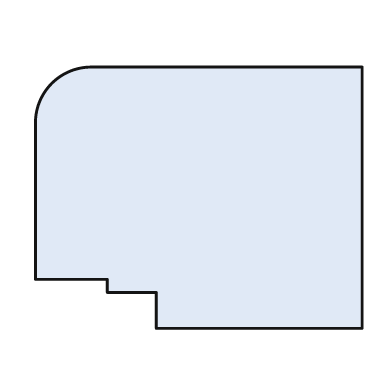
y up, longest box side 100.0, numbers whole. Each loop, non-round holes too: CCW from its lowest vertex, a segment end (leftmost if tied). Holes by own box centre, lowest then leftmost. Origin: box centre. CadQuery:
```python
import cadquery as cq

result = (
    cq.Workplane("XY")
    .moveTo(-13.0, -40.0)
    .lineTo(50.0, -40.0)
    .lineTo(50.0, 40.0)
    .lineTo(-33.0, 40.0)
    .threePointArc((-45.0, 35.0), (-50.0, 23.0))
    .lineTo(-50.0, -25.0)
    .lineTo(-28.0, -25.0)
    .lineTo(-28.0, -29.0)
    .lineTo(-13.0, -29.0)
    .close()
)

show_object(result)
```